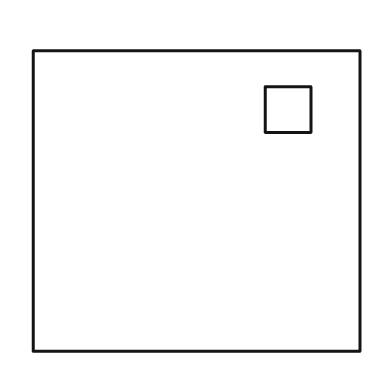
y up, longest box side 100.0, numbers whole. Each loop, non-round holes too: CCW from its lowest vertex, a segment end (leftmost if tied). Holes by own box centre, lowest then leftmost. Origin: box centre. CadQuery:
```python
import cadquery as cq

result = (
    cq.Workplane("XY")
    .moveTo(-50.0, -46.0)
    .lineTo(50.0, -46.0)
    .lineTo(50.0, 46.0)
    .lineTo(-50.0, 46.0)
    .close()
    .moveTo(21.0, 21.0)
    .lineTo(35.0, 21.0)
    .lineTo(35.0, 35.0)
    .lineTo(21.0, 35.0)
    .close()
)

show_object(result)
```